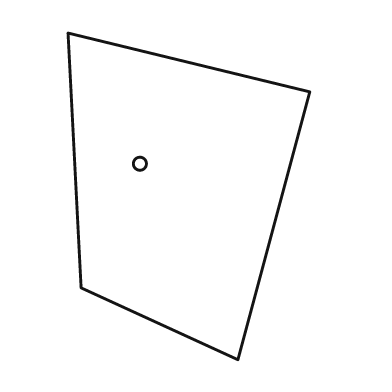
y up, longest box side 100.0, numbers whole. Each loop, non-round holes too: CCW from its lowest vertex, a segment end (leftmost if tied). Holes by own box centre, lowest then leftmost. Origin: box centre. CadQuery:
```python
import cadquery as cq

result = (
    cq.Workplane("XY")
    .moveTo(15.0, -50.0)
    .lineTo(37.0, 32.0)
    .lineTo(-37.0, 50.0)
    .lineTo(-33.0, -28.0)
    .close()
    .moveTo(-15.0, 10.0)
    .circle(2.0)
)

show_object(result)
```